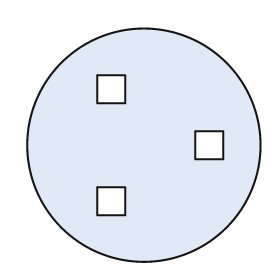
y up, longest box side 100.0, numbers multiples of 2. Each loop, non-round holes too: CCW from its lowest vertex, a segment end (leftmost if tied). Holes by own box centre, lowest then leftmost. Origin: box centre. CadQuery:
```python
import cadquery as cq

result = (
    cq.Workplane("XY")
    .moveTo(0.0, 0.0)
    .circle(50.0)
    .moveTo(-20.0, -30.0)
    .lineTo(-8.0, -30.0)
    .lineTo(-8.0, -18.0)
    .lineTo(-20.0, -18.0)
    .close()
    .moveTo(22.0, -6.0)
    .lineTo(34.0, -6.0)
    .lineTo(34.0, 6.0)
    .lineTo(22.0, 6.0)
    .close()
    .moveTo(-20.0, 18.0)
    .lineTo(-8.0, 18.0)
    .lineTo(-8.0, 30.0)
    .lineTo(-20.0, 30.0)
    .close()
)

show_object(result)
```